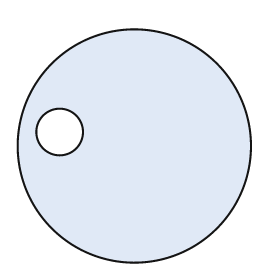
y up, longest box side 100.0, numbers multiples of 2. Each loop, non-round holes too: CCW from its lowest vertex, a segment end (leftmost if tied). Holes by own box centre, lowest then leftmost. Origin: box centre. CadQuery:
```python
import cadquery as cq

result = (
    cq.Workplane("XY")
    .moveTo(0.0, 0.0)
    .circle(50.0)
    .moveTo(-32.0, 6.0)
    .circle(10.0)
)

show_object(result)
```